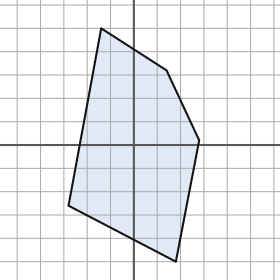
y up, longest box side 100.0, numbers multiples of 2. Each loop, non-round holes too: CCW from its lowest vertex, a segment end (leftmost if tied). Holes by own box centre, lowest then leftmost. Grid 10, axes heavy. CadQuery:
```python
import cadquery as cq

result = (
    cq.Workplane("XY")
    .moveTo(18.0, -50.0)
    .lineTo(28.0, 2.0)
    .lineTo(14.0, 32.0)
    .lineTo(-14.0, 50.0)
    .lineTo(-28.0, -26.0)
    .close()
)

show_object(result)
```